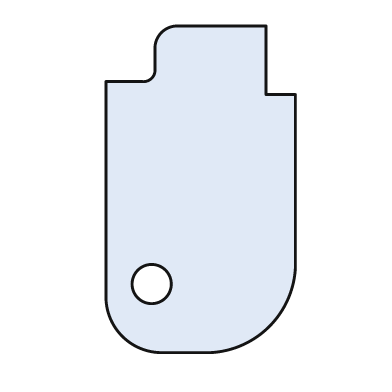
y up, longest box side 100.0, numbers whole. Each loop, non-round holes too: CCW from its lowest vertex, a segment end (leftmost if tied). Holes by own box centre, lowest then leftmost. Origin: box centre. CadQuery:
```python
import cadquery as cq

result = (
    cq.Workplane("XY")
    .moveTo(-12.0, -50.0)
    .lineTo(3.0, -50.0)
    .threePointArc((21.0, -42.0), (29.0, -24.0))
    .lineTo(29.0, 29.0)
    .lineTo(20.0, 29.0)
    .lineTo(20.0, 50.0)
    .lineTo(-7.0, 50.0)
    .threePointArc((-12.0, 48.0), (-14.0, 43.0))
    .lineTo(-14.0, 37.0)
    .threePointArc((-15.0, 34.0), (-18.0, 33.0))
    .lineTo(-29.0, 33.0)
    .lineTo(-29.0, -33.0)
    .threePointArc((-24.0, -45.0), (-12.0, -50.0))
    .close()
    .moveTo(-15.0, -29.0)
    .circle(6.0)
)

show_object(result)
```